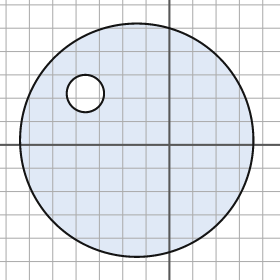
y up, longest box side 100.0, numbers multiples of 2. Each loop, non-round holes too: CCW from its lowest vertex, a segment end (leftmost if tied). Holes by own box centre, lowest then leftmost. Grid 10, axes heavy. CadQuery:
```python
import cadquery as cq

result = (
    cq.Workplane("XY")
    .moveTo(-14.0, 2.0)
    .circle(50.0)
    .moveTo(-36.0, 22.0)
    .circle(8.0)
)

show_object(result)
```